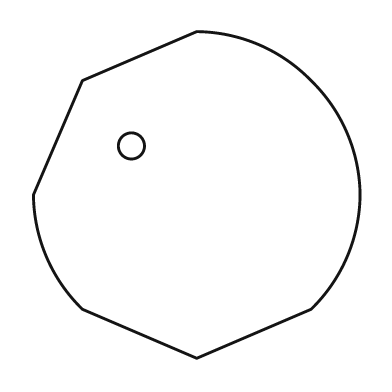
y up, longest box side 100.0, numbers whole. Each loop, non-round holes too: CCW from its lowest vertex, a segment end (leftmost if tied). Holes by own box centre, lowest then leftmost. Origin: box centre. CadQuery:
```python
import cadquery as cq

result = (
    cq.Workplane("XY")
    .moveTo(0.0, -50.0)
    .lineTo(35.0, -35.0)
    .threePointArc((46.0, -19.0), (50.0, 0.0))
    .threePointArc((46.0, 19.0), (35.0, 35.0))
    .threePointArc((19.0, 46.0), (0.0, 50.0))
    .lineTo(-35.0, 35.0)
    .lineTo(-50.0, 0.0)
    .threePointArc((-46.0, -19.0), (-35.0, -35.0))
    .close()
    .moveTo(-20.0, 15.0)
    .circle(4.0)
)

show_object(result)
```